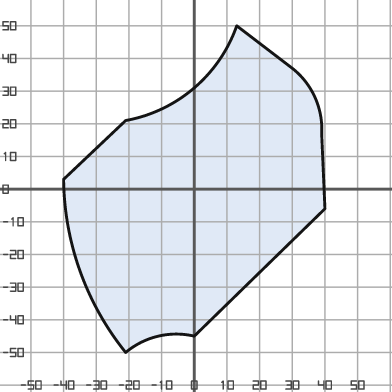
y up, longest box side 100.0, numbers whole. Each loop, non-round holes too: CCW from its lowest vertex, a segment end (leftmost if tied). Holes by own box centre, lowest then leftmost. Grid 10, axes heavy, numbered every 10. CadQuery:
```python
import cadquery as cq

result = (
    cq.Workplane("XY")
    .moveTo(-21.0, -50.0)
    .threePointArc((-11.0, -45.0), (0.0, -45.0))
    .lineTo(40.0, -6.0)
    .lineTo(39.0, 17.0)
    .threePointArc((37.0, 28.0), (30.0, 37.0))
    .lineTo(13.0, 50.0)
    .threePointArc((0.0, 31.0), (-21.0, 21.0))
    .lineTo(-40.0, 3.0)
    .threePointArc((-35.0, -25.0), (-21.0, -50.0))
    .close()
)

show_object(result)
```